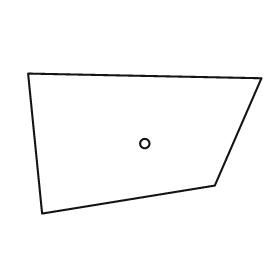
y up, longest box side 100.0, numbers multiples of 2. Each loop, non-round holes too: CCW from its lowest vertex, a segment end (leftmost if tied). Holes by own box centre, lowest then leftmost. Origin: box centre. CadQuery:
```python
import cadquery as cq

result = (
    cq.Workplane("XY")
    .moveTo(-44.0, -30.0)
    .lineTo(30.0, -18.0)
    .lineTo(50.0, 28.0)
    .lineTo(-50.0, 30.0)
    .close()
    .moveTo(0.0, 0.0)
    .circle(2.0)
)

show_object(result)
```